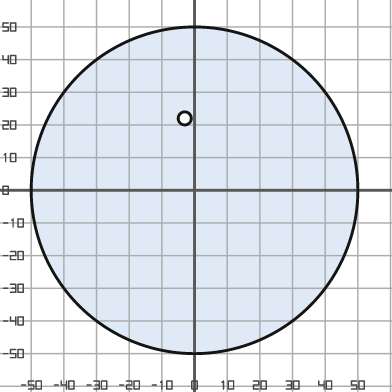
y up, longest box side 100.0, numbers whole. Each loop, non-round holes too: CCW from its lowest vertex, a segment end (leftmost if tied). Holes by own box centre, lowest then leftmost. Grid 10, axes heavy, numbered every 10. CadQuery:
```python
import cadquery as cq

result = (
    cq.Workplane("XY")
    .moveTo(0.0, 0.0)
    .circle(50.0)
    .moveTo(-3.0, 22.0)
    .circle(2.0)
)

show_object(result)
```